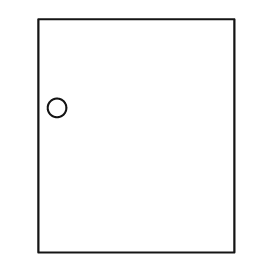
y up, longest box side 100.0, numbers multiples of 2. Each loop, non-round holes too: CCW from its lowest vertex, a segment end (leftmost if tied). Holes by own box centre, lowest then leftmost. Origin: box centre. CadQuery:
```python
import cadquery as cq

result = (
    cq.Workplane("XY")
    .moveTo(-42.0, -50.0)
    .lineTo(42.0, -50.0)
    .lineTo(42.0, 50.0)
    .lineTo(-42.0, 50.0)
    .close()
    .moveTo(-34.0, 12.0)
    .circle(4.0)
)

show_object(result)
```